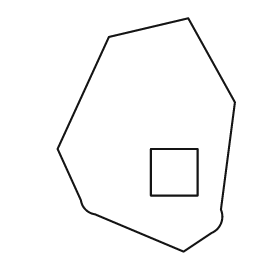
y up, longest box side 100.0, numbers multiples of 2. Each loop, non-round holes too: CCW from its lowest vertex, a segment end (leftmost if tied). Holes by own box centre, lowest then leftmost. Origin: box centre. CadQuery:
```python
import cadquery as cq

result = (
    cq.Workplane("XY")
    .moveTo(16.0, -50.0)
    .lineTo(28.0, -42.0)
    .threePointArc((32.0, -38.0), (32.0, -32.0))
    .lineTo(38.0, 14.0)
    .lineTo(18.0, 50.0)
    .lineTo(-16.0, 42.0)
    .lineTo(-38.0, -6.0)
    .lineTo(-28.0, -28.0)
    .threePointArc((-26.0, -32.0), (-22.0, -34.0))
    .close()
    .moveTo(2.0, -26.0)
    .lineTo(22.0, -26.0)
    .lineTo(22.0, -6.0)
    .lineTo(2.0, -6.0)
    .close()
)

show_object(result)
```